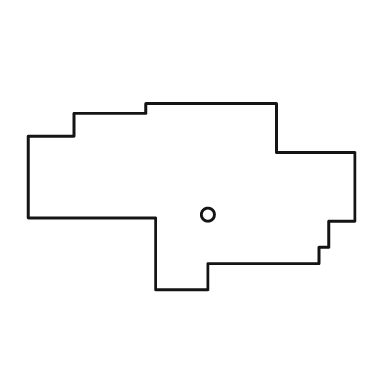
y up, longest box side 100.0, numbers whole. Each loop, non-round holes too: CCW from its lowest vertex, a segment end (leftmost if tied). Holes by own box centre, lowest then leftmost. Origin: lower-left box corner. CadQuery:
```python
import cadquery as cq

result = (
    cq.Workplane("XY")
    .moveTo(39.0, 0.0)
    .lineTo(55.0, 0.0)
    .lineTo(55.0, 8.0)
    .lineTo(89.0, 8.0)
    .lineTo(89.0, 13.0)
    .lineTo(92.0, 13.0)
    .lineTo(92.0, 21.0)
    .lineTo(100.0, 21.0)
    .lineTo(100.0, 42.0)
    .lineTo(76.0, 42.0)
    .lineTo(76.0, 57.0)
    .lineTo(36.0, 57.0)
    .lineTo(36.0, 54.0)
    .lineTo(14.0, 54.0)
    .lineTo(14.0, 47.0)
    .lineTo(0.0, 47.0)
    .lineTo(0.0, 22.0)
    .lineTo(39.0, 22.0)
    .close()
    .moveTo(55.0, 23.0)
    .circle(2.0)
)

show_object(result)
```